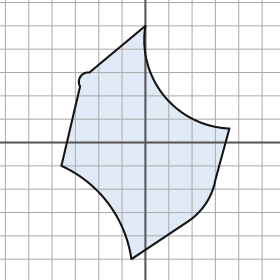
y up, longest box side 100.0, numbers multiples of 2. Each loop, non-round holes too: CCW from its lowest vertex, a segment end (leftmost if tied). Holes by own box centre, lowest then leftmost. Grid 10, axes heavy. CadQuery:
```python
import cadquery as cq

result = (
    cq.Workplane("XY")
    .moveTo(-6.0, -50.0)
    .lineTo(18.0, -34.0)
    .threePointArc((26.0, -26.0), (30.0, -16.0))
    .lineTo(36.0, 6.0)
    .threePointArc((8.0, 20.0), (0.0, 50.0))
    .lineTo(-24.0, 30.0)
    .threePointArc((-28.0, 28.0), (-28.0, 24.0))
    .lineTo(-36.0, -10.0)
    .threePointArc((-16.0, -26.0), (-6.0, -50.0))
    .close()
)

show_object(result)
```